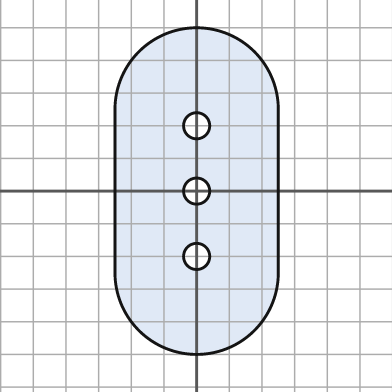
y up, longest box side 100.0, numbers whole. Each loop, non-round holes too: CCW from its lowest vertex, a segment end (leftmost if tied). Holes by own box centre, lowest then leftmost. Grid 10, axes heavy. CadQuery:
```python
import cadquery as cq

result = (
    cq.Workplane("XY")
    .moveTo(-25.0, -25.0)
    .threePointArc((0.0, -50.0), (25.0, -25.0))
    .lineTo(25.0, 25.0)
    .threePointArc((0.0, 50.0), (-25.0, 25.0))
    .close()
    .moveTo(0.0, -20.0)
    .circle(4.0)
    .moveTo(0.0, 0.0)
    .circle(4.0)
    .moveTo(0.0, 20.0)
    .circle(4.0)
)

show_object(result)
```